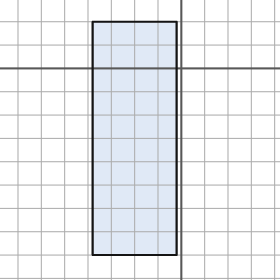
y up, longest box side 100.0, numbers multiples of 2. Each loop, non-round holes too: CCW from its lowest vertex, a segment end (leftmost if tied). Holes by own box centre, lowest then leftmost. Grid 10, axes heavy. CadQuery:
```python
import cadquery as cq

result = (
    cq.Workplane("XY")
    .moveTo(-38.0, -80.0)
    .lineTo(-2.0, -80.0)
    .lineTo(-2.0, 20.0)
    .lineTo(-38.0, 20.0)
    .close()
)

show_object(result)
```